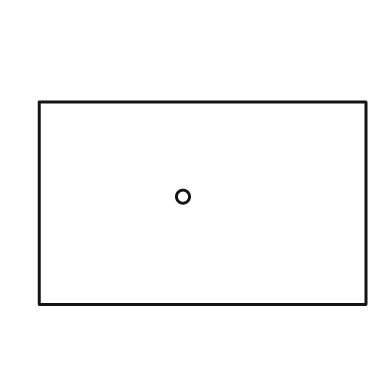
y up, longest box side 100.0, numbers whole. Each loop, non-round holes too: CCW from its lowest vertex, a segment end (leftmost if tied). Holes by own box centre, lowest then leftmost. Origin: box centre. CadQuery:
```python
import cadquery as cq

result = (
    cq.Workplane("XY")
    .moveTo(-50.0, -31.0)
    .lineTo(50.0, -31.0)
    .lineTo(50.0, 31.0)
    .lineTo(-50.0, 31.0)
    .close()
    .moveTo(-6.0, 2.0)
    .circle(2.0)
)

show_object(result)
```